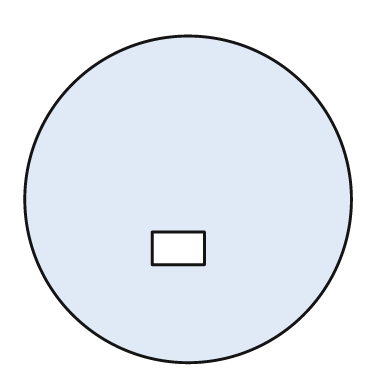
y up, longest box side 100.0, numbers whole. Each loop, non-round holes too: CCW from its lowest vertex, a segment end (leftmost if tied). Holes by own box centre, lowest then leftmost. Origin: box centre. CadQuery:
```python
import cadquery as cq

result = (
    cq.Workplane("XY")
    .moveTo(0.0, 0.0)
    .circle(50.0)
    .moveTo(-11.0, -20.0)
    .lineTo(5.0, -20.0)
    .lineTo(5.0, -10.0)
    .lineTo(-11.0, -10.0)
    .close()
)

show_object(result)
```